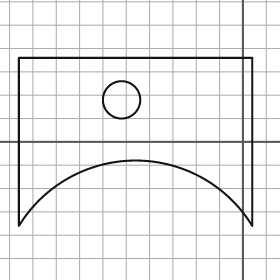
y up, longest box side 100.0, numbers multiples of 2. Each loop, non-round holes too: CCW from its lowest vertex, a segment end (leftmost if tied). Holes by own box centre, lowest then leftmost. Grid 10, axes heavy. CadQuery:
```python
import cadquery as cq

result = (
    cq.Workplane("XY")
    .moveTo(-96.0, -36.0)
    .threePointArc((-46.0, -8.0), (4.0, -36.0))
    .lineTo(4.0, 36.0)
    .lineTo(-96.0, 36.0)
    .close()
    .moveTo(-52.0, 18.0)
    .circle(8.0)
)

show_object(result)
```